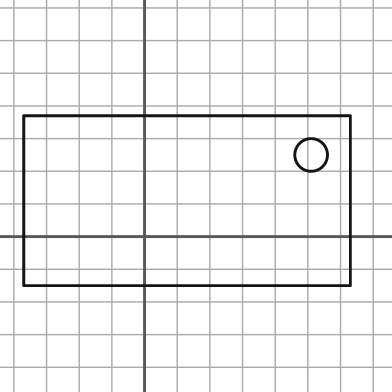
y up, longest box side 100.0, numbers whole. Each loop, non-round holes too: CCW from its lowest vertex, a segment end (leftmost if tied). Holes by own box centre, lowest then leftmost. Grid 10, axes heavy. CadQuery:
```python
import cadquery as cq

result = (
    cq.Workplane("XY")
    .moveTo(-37.0, -15.0)
    .lineTo(63.0, -15.0)
    .lineTo(63.0, 37.0)
    .lineTo(-37.0, 37.0)
    .close()
    .moveTo(51.0, 25.0)
    .circle(5.0)
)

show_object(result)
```